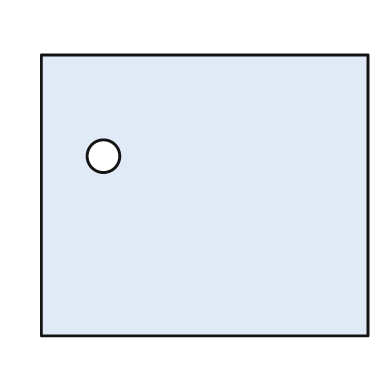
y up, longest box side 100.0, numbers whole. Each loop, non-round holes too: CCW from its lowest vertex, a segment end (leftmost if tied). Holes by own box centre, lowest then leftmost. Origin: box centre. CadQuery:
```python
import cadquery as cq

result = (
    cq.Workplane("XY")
    .moveTo(-50.0, -43.0)
    .lineTo(50.0, -43.0)
    .lineTo(50.0, 43.0)
    .lineTo(-50.0, 43.0)
    .close()
    .moveTo(-31.0, 12.0)
    .circle(5.0)
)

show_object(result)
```